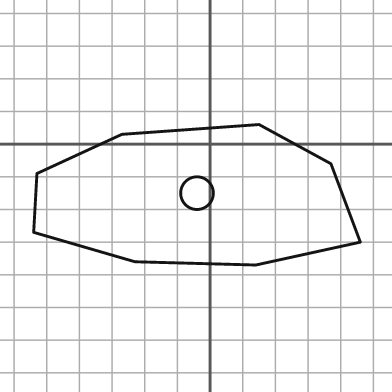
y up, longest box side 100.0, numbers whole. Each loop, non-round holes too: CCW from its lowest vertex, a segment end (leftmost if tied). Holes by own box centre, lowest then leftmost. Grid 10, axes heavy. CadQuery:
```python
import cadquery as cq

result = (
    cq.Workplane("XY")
    .moveTo(14.0, -37.0)
    .lineTo(46.0, -30.0)
    .lineTo(37.0, -6.0)
    .lineTo(15.0, 6.0)
    .lineTo(-27.0, 3.0)
    .lineTo(-53.0, -9.0)
    .lineTo(-54.0, -27.0)
    .lineTo(-23.0, -36.0)
    .close()
    .moveTo(-4.0, -15.0)
    .circle(5.0)
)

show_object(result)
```